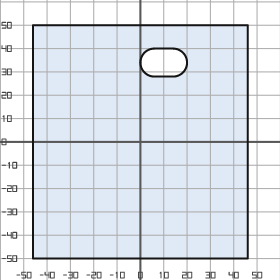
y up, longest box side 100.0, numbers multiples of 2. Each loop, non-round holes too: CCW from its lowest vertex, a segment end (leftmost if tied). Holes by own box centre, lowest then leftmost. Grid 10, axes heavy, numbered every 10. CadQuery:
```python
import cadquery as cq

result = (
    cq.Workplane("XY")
    .moveTo(-46.0, -50.0)
    .lineTo(46.0, -50.0)
    .lineTo(46.0, 50.0)
    .lineTo(-46.0, 50.0)
    .close()
    .moveTo(6.0, 28.0)
    .lineTo(14.0, 28.0)
    .threePointArc((20.0, 34.0), (14.0, 40.0))
    .lineTo(6.0, 40.0)
    .threePointArc((0.0, 34.0), (6.0, 28.0))
    .close()
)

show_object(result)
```